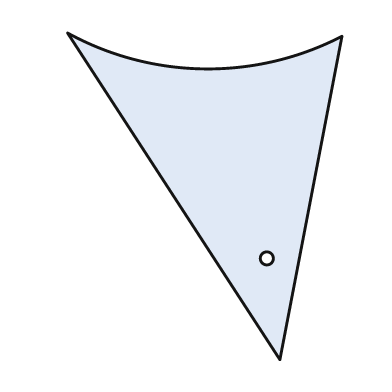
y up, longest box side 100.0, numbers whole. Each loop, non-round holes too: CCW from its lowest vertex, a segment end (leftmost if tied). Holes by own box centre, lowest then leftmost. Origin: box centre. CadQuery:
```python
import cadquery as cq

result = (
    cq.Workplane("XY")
    .moveTo(23.0, -50.0)
    .lineTo(42.0, 49.0)
    .threePointArc((0.0, 39.0), (-42.0, 50.0))
    .close()
    .moveTo(19.0, -19.0)
    .circle(2.0)
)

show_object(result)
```